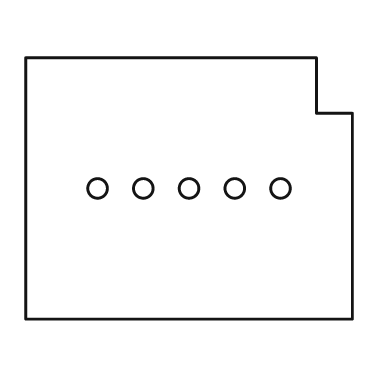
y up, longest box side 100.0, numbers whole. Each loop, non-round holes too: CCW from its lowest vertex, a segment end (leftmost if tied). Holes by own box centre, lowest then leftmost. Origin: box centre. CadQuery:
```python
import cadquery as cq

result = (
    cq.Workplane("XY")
    .moveTo(-50.0, -40.0)
    .lineTo(50.0, -40.0)
    .lineTo(50.0, 23.0)
    .lineTo(39.0, 23.0)
    .lineTo(39.0, 40.0)
    .lineTo(-50.0, 40.0)
    .close()
    .moveTo(-28.0, 0.0)
    .circle(3.0)
    .moveTo(-14.0, 0.0)
    .circle(3.0)
    .moveTo(0.0, 0.0)
    .circle(3.0)
    .moveTo(14.0, 0.0)
    .circle(3.0)
    .moveTo(28.0, 0.0)
    .circle(3.0)
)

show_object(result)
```